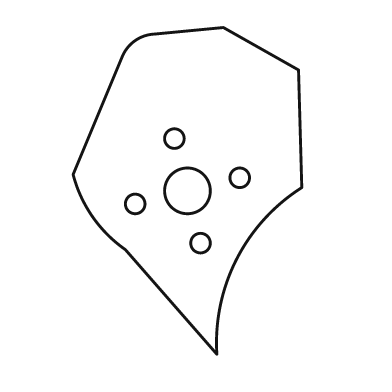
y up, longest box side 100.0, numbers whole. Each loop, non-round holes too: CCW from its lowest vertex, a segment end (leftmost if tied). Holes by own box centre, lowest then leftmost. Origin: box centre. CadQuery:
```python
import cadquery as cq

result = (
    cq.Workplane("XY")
    .moveTo(9.0, -50.0)
    .threePointArc((15.0, -21.0), (35.0, 1.0))
    .lineTo(34.0, 37.0)
    .lineTo(11.0, 50.0)
    .lineTo(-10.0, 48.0)
    .threePointArc((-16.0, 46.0), (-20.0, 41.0))
    .lineTo(-35.0, 5.0)
    .threePointArc((-29.0, -8.0), (-19.0, -18.0))
    .close()
    .moveTo(4.0, -16.0)
    .circle(3.0)
    .moveTo(-16.0, -4.0)
    .circle(3.0)
    .moveTo(0.0, 0.0)
    .circle(7.0)
    .moveTo(16.0, 4.0)
    .circle(3.0)
    .moveTo(-4.0, 16.0)
    .circle(3.0)
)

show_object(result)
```